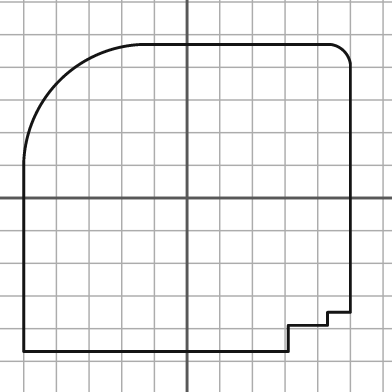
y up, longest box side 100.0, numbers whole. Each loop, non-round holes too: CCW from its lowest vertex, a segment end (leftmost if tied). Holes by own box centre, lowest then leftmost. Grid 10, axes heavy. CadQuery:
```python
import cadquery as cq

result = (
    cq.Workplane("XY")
    .moveTo(-50.0, -47.0)
    .lineTo(31.0, -47.0)
    .lineTo(31.0, -39.0)
    .lineTo(43.0, -39.0)
    .lineTo(43.0, -35.0)
    .lineTo(50.0, -35.0)
    .lineTo(50.0, 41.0)
    .threePointArc((48.0, 45.0), (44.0, 47.0))
    .lineTo(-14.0, 47.0)
    .threePointArc((-39.0, 36.0), (-50.0, 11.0))
    .close()
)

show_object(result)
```